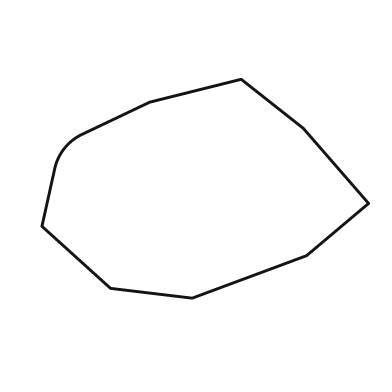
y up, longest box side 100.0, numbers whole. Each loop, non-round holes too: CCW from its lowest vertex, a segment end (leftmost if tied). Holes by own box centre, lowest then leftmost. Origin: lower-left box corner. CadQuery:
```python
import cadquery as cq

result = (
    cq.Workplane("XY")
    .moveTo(46.0, 0.0)
    .lineTo(81.0, 13.0)
    .lineTo(100.0, 29.0)
    .lineTo(80.0, 52.0)
    .lineTo(61.0, 67.0)
    .lineTo(33.0, 60.0)
    .lineTo(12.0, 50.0)
    .threePointArc((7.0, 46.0), (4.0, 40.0))
    .lineTo(0.0, 22.0)
    .lineTo(21.0, 3.0)
    .close()
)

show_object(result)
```